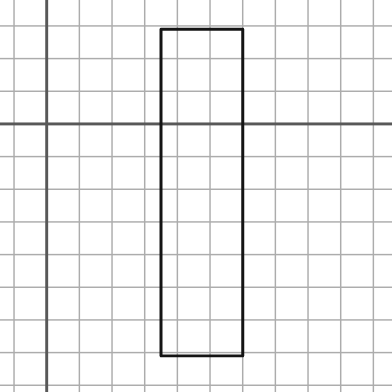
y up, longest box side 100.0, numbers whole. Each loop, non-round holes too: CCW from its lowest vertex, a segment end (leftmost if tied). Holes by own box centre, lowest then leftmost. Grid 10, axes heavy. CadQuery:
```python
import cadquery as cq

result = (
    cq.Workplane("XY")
    .moveTo(35.0, -71.0)
    .lineTo(60.0, -71.0)
    .lineTo(60.0, 29.0)
    .lineTo(35.0, 29.0)
    .close()
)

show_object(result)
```